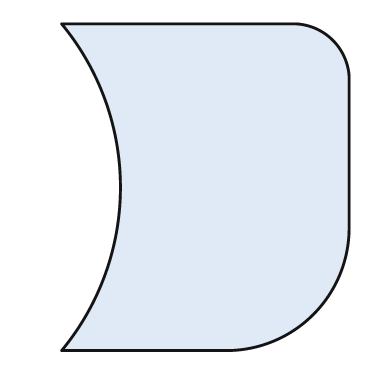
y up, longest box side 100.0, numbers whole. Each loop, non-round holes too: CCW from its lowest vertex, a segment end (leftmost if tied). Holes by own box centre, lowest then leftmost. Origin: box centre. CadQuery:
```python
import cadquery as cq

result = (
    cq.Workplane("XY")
    .moveTo(-44.0, -50.0)
    .lineTo(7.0, -50.0)
    .threePointArc((33.0, -39.0), (44.0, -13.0))
    .lineTo(44.0, 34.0)
    .threePointArc((39.0, 45.0), (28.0, 50.0))
    .lineTo(-44.0, 50.0)
    .threePointArc((-26.0, 0.0), (-44.0, -50.0))
    .close()
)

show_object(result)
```